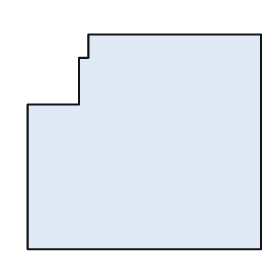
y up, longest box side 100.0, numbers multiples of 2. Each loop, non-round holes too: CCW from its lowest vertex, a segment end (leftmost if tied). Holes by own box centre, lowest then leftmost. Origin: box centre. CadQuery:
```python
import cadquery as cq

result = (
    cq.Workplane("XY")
    .moveTo(-50.0, -46.0)
    .lineTo(50.0, -46.0)
    .lineTo(50.0, 46.0)
    .lineTo(-24.0, 46.0)
    .lineTo(-24.0, 36.0)
    .lineTo(-28.0, 36.0)
    .lineTo(-28.0, 16.0)
    .lineTo(-50.0, 16.0)
    .close()
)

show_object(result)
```